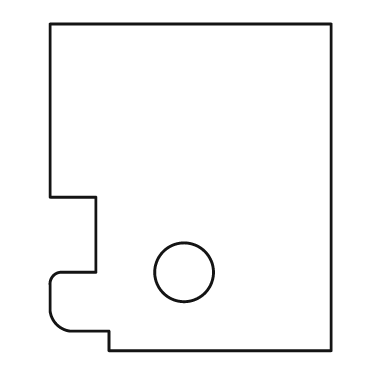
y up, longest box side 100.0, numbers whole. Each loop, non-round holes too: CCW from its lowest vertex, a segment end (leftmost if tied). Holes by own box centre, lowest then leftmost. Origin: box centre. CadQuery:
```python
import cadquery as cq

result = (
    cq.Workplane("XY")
    .moveTo(-25.0, -50.0)
    .lineTo(43.0, -50.0)
    .lineTo(43.0, 50.0)
    .lineTo(-43.0, 50.0)
    .lineTo(-43.0, -3.0)
    .lineTo(-29.0, -3.0)
    .lineTo(-29.0, -26.0)
    .lineTo(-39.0, -26.0)
    .threePointArc((-42.0, -27.0), (-43.0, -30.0))
    .lineTo(-43.0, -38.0)
    .threePointArc((-41.0, -42.0), (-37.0, -44.0))
    .lineTo(-25.0, -44.0)
    .close()
    .moveTo(-2.0, -26.0)
    .circle(9.0)
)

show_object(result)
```